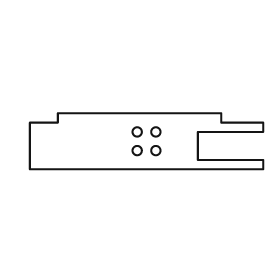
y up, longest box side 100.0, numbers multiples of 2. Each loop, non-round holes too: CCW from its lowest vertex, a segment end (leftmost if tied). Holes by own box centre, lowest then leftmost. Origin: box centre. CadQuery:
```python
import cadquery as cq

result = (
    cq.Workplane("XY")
    .moveTo(-50.0, -12.0)
    .lineTo(50.0, -12.0)
    .lineTo(50.0, -8.0)
    .lineTo(22.0, -8.0)
    .lineTo(22.0, 4.0)
    .lineTo(50.0, 4.0)
    .lineTo(50.0, 8.0)
    .lineTo(32.0, 8.0)
    .lineTo(32.0, 12.0)
    .lineTo(-38.0, 12.0)
    .lineTo(-38.0, 8.0)
    .lineTo(-50.0, 8.0)
    .close()
    .moveTo(-4.0, -4.0)
    .circle(2.0)
    .moveTo(4.0, -4.0)
    .circle(2.0)
    .moveTo(-4.0, 4.0)
    .circle(2.0)
    .moveTo(4.0, 4.0)
    .circle(2.0)
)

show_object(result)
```